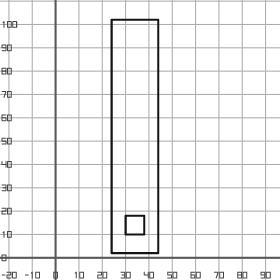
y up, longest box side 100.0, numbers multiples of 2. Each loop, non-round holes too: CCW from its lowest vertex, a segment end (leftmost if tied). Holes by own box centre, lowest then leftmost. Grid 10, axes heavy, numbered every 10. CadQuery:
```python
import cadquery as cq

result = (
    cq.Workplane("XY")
    .moveTo(24.0, 2.0)
    .lineTo(44.0, 2.0)
    .lineTo(44.0, 102.0)
    .lineTo(24.0, 102.0)
    .close()
    .moveTo(30.0, 10.0)
    .lineTo(38.0, 10.0)
    .lineTo(38.0, 18.0)
    .lineTo(30.0, 18.0)
    .close()
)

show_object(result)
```